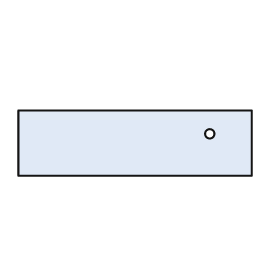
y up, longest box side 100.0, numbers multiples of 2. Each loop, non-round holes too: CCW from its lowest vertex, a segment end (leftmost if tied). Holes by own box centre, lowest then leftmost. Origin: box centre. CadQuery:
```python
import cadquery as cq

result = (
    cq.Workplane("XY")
    .moveTo(-50.0, -14.0)
    .lineTo(50.0, -14.0)
    .lineTo(50.0, 14.0)
    .lineTo(-50.0, 14.0)
    .close()
    .moveTo(32.0, 4.0)
    .circle(2.0)
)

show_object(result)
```